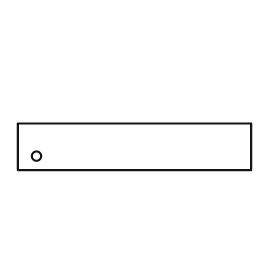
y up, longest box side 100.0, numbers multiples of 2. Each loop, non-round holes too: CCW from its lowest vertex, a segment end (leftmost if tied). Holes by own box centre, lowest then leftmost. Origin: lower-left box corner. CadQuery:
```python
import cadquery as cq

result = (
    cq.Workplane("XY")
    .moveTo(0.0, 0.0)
    .lineTo(100.0, 0.0)
    .lineTo(100.0, 20.0)
    .lineTo(0.0, 20.0)
    .close()
    .moveTo(8.0, 6.0)
    .circle(2.0)
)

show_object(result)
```